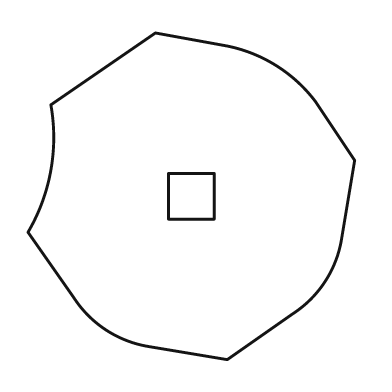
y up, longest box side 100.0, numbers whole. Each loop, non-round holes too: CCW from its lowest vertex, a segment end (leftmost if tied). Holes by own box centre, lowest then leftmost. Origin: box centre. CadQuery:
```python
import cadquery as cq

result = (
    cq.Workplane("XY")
    .moveTo(11.0, -50.0)
    .lineTo(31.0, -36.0)
    .threePointArc((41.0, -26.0), (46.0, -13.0))
    .lineTo(50.0, 11.0)
    .lineTo(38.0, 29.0)
    .threePointArc((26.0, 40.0), (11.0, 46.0))
    .lineTo(-11.0, 50.0)
    .lineTo(-43.0, 28.0)
    .threePointArc((-43.0, 8.0), (-50.0, -11.0))
    .lineTo(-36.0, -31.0)
    .threePointArc((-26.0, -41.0), (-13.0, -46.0))
    .close()
    .moveTo(-7.0, -7.0)
    .lineTo(7.0, -7.0)
    .lineTo(7.0, 7.0)
    .lineTo(-7.0, 7.0)
    .close()
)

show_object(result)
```